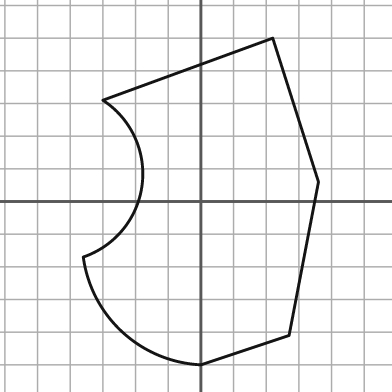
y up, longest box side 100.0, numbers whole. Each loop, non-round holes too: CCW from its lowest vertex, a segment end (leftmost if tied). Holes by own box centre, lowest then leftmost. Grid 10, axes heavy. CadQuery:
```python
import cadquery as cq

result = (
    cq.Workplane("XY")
    .moveTo(0.0, -50.0)
    .lineTo(27.0, -41.0)
    .lineTo(36.0, 6.0)
    .lineTo(22.0, 50.0)
    .lineTo(-30.0, 31.0)
    .threePointArc((-18.0, 5.0), (-36.0, -17.0))
    .threePointArc((-24.0, -40.0), (0.0, -50.0))
    .close()
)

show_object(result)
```